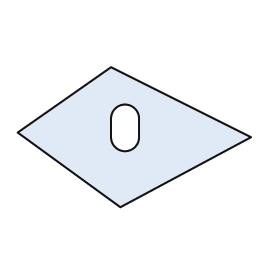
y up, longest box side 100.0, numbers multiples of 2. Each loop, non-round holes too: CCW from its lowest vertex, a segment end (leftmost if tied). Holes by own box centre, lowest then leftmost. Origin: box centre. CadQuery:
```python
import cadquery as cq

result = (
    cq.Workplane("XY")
    .moveTo(-6.0, -30.0)
    .lineTo(50.0, 0.0)
    .lineTo(-10.0, 30.0)
    .lineTo(-50.0, 2.0)
    .close()
    .moveTo(-10.0, 0.0)
    .threePointArc((-4.0, -6.0), (2.0, 0.0))
    .lineTo(2.0, 8.0)
    .threePointArc((-4.0, 14.0), (-10.0, 8.0))
    .close()
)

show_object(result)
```